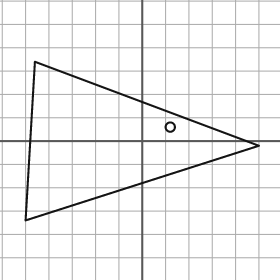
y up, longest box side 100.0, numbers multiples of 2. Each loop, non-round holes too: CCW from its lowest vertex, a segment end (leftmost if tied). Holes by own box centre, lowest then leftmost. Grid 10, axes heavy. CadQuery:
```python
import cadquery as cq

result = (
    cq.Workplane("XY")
    .moveTo(-50.0, -34.0)
    .lineTo(50.0, -2.0)
    .lineTo(-46.0, 34.0)
    .close()
    .moveTo(12.0, 6.0)
    .circle(2.0)
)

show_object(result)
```